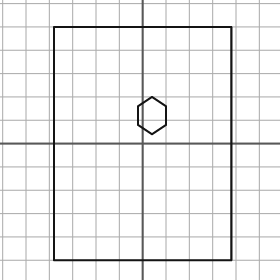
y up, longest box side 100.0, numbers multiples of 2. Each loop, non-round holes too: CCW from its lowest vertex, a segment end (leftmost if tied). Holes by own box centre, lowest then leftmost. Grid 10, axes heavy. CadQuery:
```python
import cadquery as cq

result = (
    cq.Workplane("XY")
    .moveTo(-38.0, -50.0)
    .lineTo(38.0, -50.0)
    .lineTo(38.0, 50.0)
    .lineTo(-38.0, 50.0)
    .close()
    .moveTo(4.0, 4.0)
    .lineTo(10.0, 8.0)
    .lineTo(10.0, 16.0)
    .lineTo(4.0, 20.0)
    .lineTo(-2.0, 16.0)
    .lineTo(-2.0, 8.0)
    .close()
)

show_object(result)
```